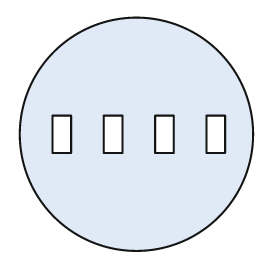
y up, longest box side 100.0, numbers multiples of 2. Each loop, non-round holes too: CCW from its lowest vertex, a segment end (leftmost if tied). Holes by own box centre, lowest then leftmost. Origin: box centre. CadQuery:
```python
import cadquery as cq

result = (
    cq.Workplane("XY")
    .moveTo(0.0, 0.0)
    .circle(50.0)
    .moveTo(-36.0, -8.0)
    .lineTo(-28.0, -8.0)
    .lineTo(-28.0, 8.0)
    .lineTo(-36.0, 8.0)
    .close()
    .moveTo(-14.0, -8.0)
    .lineTo(-6.0, -8.0)
    .lineTo(-6.0, 8.0)
    .lineTo(-14.0, 8.0)
    .close()
    .moveTo(8.0, -8.0)
    .lineTo(16.0, -8.0)
    .lineTo(16.0, 8.0)
    .lineTo(8.0, 8.0)
    .close()
    .moveTo(30.0, -8.0)
    .lineTo(38.0, -8.0)
    .lineTo(38.0, 8.0)
    .lineTo(30.0, 8.0)
    .close()
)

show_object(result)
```